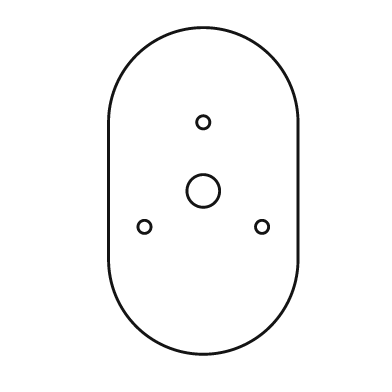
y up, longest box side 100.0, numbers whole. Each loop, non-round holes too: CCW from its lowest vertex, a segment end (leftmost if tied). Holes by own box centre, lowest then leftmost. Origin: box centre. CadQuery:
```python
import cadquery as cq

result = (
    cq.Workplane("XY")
    .moveTo(-29.0, -21.0)
    .threePointArc((0.0, -50.0), (29.0, -21.0))
    .lineTo(29.0, 21.0)
    .threePointArc((0.0, 50.0), (-29.0, 21.0))
    .close()
    .moveTo(-18.0, -11.0)
    .circle(2.0)
    .moveTo(18.0, -11.0)
    .circle(2.0)
    .moveTo(0.0, 0.0)
    .circle(5.0)
    .moveTo(0.0, 21.0)
    .circle(2.0)
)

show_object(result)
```